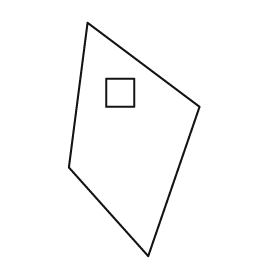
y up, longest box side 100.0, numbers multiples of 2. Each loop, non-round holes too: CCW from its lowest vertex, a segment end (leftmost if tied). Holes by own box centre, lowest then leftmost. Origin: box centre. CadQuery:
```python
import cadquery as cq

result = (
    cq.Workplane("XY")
    .moveTo(6.0, -50.0)
    .lineTo(28.0, 14.0)
    .lineTo(-20.0, 50.0)
    .lineTo(-28.0, -12.0)
    .close()
    .moveTo(-12.0, 14.0)
    .lineTo(0.0, 14.0)
    .lineTo(0.0, 26.0)
    .lineTo(-12.0, 26.0)
    .close()
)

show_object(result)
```